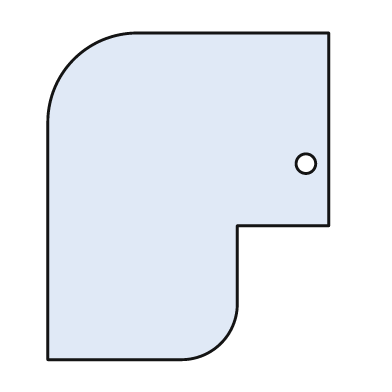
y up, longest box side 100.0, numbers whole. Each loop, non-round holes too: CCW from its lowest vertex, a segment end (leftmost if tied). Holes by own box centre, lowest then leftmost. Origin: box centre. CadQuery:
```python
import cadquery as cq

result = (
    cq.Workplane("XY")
    .moveTo(-43.0, -50.0)
    .lineTo(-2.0, -50.0)
    .threePointArc((10.0, -45.0), (15.0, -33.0))
    .lineTo(15.0, -9.0)
    .lineTo(43.0, -9.0)
    .lineTo(43.0, 50.0)
    .lineTo(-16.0, 50.0)
    .threePointArc((-35.0, 42.0), (-43.0, 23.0))
    .close()
    .moveTo(36.0, 10.0)
    .circle(3.0)
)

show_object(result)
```